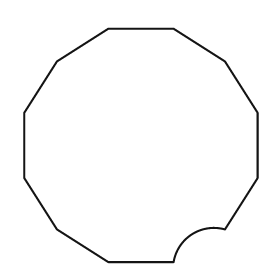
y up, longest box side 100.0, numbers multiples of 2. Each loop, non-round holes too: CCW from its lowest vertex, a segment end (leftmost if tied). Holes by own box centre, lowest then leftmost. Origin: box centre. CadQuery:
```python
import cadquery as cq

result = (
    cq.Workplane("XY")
    .moveTo(-14.0, -50.0)
    .lineTo(14.0, -50.0)
    .threePointArc((22.0, -38.0), (36.0, -36.0))
    .lineTo(50.0, -14.0)
    .lineTo(50.0, 14.0)
    .lineTo(36.0, 36.0)
    .lineTo(14.0, 50.0)
    .lineTo(-14.0, 50.0)
    .lineTo(-36.0, 36.0)
    .lineTo(-50.0, 14.0)
    .lineTo(-50.0, -14.0)
    .lineTo(-36.0, -36.0)
    .close()
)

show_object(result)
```